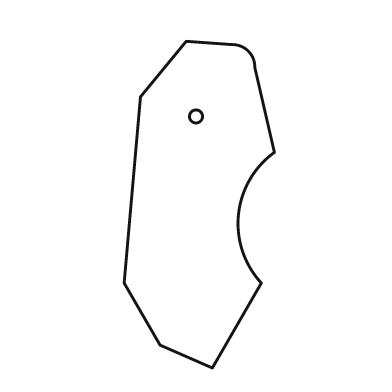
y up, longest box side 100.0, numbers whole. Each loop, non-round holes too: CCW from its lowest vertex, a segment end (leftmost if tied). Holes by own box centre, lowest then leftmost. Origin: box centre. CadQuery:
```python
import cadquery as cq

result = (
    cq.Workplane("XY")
    .moveTo(4.0, -50.0)
    .lineTo(19.0, -24.0)
    .threePointArc((12.0, -3.0), (23.0, 16.0))
    .lineTo(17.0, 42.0)
    .threePointArc((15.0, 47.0), (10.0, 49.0))
    .lineTo(-4.0, 50.0)
    .lineTo(-18.0, 33.0)
    .lineTo(-23.0, -24.0)
    .lineTo(-12.0, -43.0)
    .close()
    .moveTo(-1.0, 27.0)
    .circle(2.0)
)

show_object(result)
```